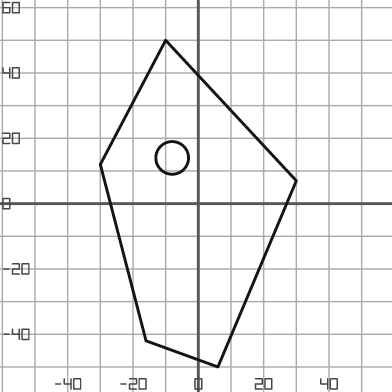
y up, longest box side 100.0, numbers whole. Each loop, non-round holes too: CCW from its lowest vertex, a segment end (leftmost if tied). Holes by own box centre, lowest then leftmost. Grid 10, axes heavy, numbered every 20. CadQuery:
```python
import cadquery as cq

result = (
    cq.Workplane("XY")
    .moveTo(6.0, -50.0)
    .lineTo(30.0, 7.0)
    .lineTo(-10.0, 50.0)
    .lineTo(-30.0, 12.0)
    .lineTo(-16.0, -42.0)
    .close()
    .moveTo(-8.0, 14.0)
    .circle(5.0)
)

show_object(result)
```